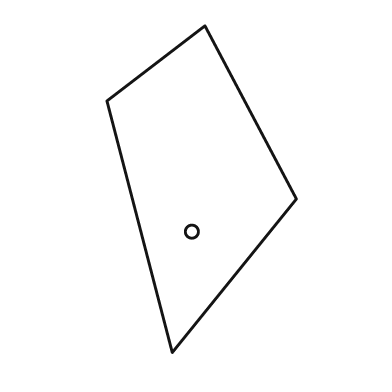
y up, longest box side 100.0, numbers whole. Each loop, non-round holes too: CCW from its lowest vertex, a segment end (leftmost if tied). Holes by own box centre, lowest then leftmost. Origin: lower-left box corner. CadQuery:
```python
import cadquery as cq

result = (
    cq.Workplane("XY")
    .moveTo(20.0, 0.0)
    .lineTo(58.0, 47.0)
    .lineTo(30.0, 100.0)
    .lineTo(0.0, 77.0)
    .close()
    .moveTo(26.0, 37.0)
    .circle(2.0)
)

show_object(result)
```